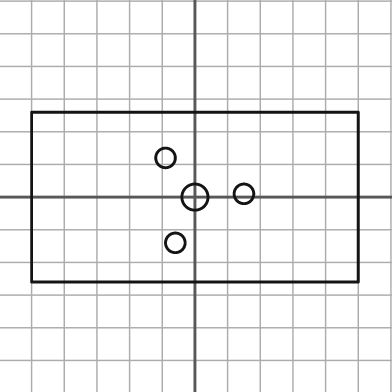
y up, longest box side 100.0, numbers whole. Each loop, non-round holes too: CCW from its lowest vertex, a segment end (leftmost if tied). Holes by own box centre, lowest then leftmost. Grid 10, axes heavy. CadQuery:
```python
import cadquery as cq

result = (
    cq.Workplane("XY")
    .moveTo(-50.0, -26.0)
    .lineTo(50.0, -26.0)
    .lineTo(50.0, 26.0)
    .lineTo(-50.0, 26.0)
    .close()
    .moveTo(-6.0, -14.0)
    .circle(3.0)
    .moveTo(0.0, 0.0)
    .circle(4.0)
    .moveTo(15.0, 1.0)
    .circle(3.0)
    .moveTo(-9.0, 12.0)
    .circle(3.0)
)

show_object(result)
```